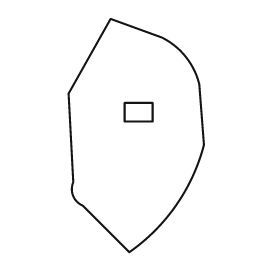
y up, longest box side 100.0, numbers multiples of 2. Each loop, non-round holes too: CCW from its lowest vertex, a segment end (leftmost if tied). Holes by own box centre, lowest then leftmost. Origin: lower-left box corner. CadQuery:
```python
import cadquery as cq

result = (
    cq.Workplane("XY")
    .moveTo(26.0, 0.0)
    .threePointArc((46.0, 20.0), (58.0, 46.0))
    .lineTo(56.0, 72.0)
    .threePointArc((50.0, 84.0), (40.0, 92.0))
    .lineTo(18.0, 100.0)
    .lineTo(0.0, 68.0)
    .lineTo(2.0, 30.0)
    .threePointArc((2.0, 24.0), (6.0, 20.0))
    .close()
    .moveTo(24.0, 56.0)
    .lineTo(36.0, 56.0)
    .lineTo(36.0, 64.0)
    .lineTo(24.0, 64.0)
    .close()
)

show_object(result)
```